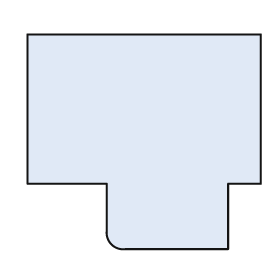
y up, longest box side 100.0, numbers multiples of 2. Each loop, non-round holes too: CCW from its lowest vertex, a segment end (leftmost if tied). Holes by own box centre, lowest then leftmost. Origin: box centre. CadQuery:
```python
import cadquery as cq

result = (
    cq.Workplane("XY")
    .moveTo(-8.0, -46.0)
    .lineTo(36.0, -46.0)
    .lineTo(36.0, -18.0)
    .lineTo(50.0, -18.0)
    .lineTo(50.0, 46.0)
    .lineTo(-50.0, 46.0)
    .lineTo(-50.0, -18.0)
    .lineTo(-16.0, -18.0)
    .lineTo(-16.0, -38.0)
    .threePointArc((-14.0, -44.0), (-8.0, -46.0))
    .close()
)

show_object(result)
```